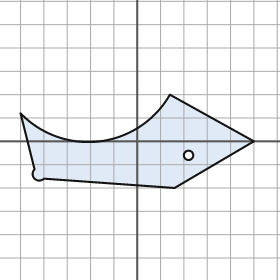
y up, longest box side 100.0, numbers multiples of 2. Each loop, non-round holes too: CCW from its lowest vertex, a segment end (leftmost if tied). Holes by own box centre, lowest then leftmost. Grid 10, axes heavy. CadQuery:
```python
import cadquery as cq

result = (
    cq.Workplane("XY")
    .moveTo(16.0, -20.0)
    .lineTo(50.0, 0.0)
    .lineTo(14.0, 20.0)
    .threePointArc((-16.0, 0.0), (-50.0, 12.0))
    .lineTo(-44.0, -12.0)
    .threePointArc((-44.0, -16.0), (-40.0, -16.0))
    .close()
    .moveTo(22.0, -6.0)
    .circle(2.0)
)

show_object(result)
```